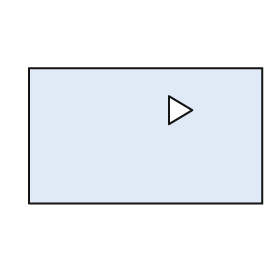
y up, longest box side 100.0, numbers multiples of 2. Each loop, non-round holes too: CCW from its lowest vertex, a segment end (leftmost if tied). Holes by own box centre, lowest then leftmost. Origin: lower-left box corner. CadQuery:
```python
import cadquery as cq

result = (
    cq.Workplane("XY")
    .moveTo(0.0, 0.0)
    .lineTo(100.0, 0.0)
    .lineTo(100.0, 58.0)
    .lineTo(0.0, 58.0)
    .close()
    .moveTo(60.0, 34.0)
    .lineTo(70.0, 40.0)
    .lineTo(60.0, 46.0)
    .close()
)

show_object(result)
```